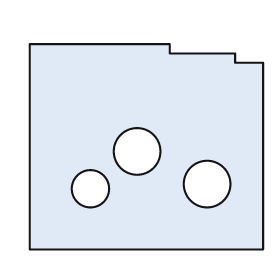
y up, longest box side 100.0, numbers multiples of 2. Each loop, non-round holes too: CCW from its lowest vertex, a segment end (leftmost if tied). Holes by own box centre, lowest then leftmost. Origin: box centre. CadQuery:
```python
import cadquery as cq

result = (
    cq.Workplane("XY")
    .moveTo(-50.0, -44.0)
    .lineTo(50.0, -44.0)
    .lineTo(50.0, 36.0)
    .lineTo(38.0, 36.0)
    .lineTo(38.0, 40.0)
    .lineTo(10.0, 40.0)
    .lineTo(10.0, 44.0)
    .lineTo(-50.0, 44.0)
    .close()
    .moveTo(-24.0, -18.0)
    .circle(8.0)
    .moveTo(26.0, -16.0)
    .circle(10.0)
    .moveTo(-4.0, -2.0)
    .circle(10.0)
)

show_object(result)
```